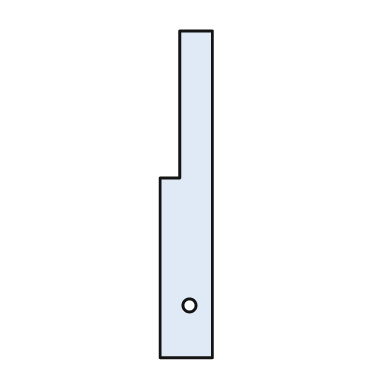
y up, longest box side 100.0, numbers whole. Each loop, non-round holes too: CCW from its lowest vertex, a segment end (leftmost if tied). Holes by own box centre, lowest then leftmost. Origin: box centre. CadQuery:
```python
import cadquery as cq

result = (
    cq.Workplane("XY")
    .moveTo(-8.0, -50.0)
    .lineTo(8.0, -50.0)
    .lineTo(8.0, 50.0)
    .lineTo(-2.0, 50.0)
    .lineTo(-2.0, 5.0)
    .lineTo(-8.0, 5.0)
    .close()
    .moveTo(1.0, -34.0)
    .circle(2.0)
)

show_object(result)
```